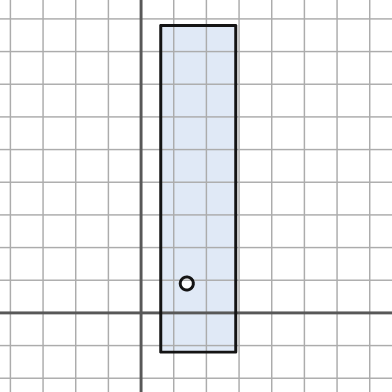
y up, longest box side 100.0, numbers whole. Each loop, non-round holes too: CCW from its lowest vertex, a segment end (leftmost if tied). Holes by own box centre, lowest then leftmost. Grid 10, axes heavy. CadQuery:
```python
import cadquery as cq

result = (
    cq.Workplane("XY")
    .moveTo(6.0, -12.0)
    .lineTo(29.0, -12.0)
    .lineTo(29.0, 88.0)
    .lineTo(6.0, 88.0)
    .close()
    .moveTo(14.0, 9.0)
    .circle(2.0)
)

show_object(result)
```